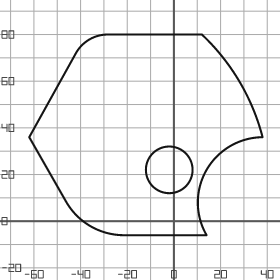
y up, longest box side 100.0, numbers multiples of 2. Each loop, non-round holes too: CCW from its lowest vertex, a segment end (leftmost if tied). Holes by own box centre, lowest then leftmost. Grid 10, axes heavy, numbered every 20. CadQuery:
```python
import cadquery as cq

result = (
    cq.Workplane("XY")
    .moveTo(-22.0, -6.0)
    .lineTo(14.0, -6.0)
    .threePointArc((14.0, 22.0), (38.0, 36.0))
    .threePointArc((28.0, 60.0), (12.0, 80.0))
    .lineTo(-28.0, 80.0)
    .threePointArc((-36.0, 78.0), (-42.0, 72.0))
    .lineTo(-62.0, 36.0)
    .lineTo(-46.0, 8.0)
    .threePointArc((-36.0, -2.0), (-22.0, -6.0))
    .close()
    .moveTo(-2.0, 22.0)
    .circle(10.0)
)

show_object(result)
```